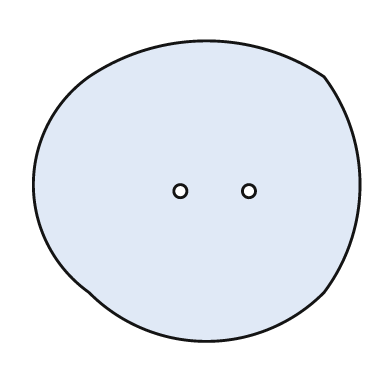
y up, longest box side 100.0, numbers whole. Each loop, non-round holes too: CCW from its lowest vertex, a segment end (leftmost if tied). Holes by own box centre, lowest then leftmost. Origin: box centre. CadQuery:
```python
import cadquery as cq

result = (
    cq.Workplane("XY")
    .moveTo(-33.0, -31.0)
    .threePointArc((3.0, -46.0), (39.0, -31.0))
    .threePointArc((50.0, 2.0), (39.0, 35.0))
    .threePointArc((3.0, 46.0), (-33.0, 35.0))
    .threePointArc((-50.0, 2.0), (-33.0, -31.0))
    .close()
    .moveTo(-5.0, 0.0)
    .circle(2.0)
    .moveTo(16.0, 0.0)
    .circle(2.0)
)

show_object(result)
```